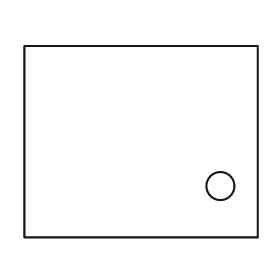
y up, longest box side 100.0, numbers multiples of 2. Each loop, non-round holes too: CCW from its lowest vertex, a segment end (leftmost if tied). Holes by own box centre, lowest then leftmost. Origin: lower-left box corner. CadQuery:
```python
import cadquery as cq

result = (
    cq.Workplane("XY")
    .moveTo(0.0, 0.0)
    .lineTo(100.0, 0.0)
    .lineTo(100.0, 82.0)
    .lineTo(0.0, 82.0)
    .close()
    .moveTo(84.0, 22.0)
    .circle(6.0)
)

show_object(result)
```